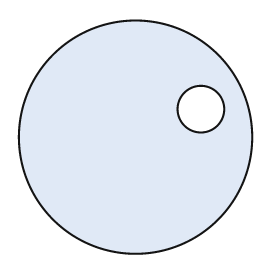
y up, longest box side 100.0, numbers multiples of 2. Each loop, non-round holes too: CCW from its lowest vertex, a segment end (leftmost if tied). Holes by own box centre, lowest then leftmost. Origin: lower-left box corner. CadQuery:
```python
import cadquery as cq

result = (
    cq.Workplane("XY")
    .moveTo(50.0, 50.0)
    .circle(50.0)
    .moveTo(78.0, 62.0)
    .circle(10.0)
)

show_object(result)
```